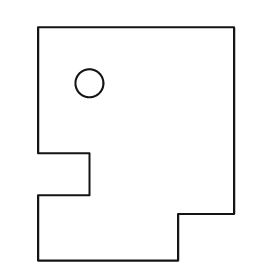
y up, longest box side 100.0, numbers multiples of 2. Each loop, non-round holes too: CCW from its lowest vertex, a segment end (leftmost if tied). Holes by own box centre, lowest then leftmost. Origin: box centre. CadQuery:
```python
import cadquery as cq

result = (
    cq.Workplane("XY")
    .moveTo(-42.0, -50.0)
    .lineTo(18.0, -50.0)
    .lineTo(18.0, -30.0)
    .lineTo(42.0, -30.0)
    .lineTo(42.0, 50.0)
    .lineTo(-42.0, 50.0)
    .lineTo(-42.0, -4.0)
    .lineTo(-20.0, -4.0)
    .lineTo(-20.0, -22.0)
    .lineTo(-42.0, -22.0)
    .close()
    .moveTo(-20.0, 26.0)
    .circle(6.0)
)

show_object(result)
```